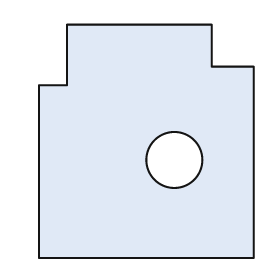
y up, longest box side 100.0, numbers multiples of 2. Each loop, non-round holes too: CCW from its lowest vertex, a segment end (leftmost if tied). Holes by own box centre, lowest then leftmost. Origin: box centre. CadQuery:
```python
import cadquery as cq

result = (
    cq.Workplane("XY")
    .moveTo(-46.0, -50.0)
    .lineTo(46.0, -50.0)
    .lineTo(46.0, 32.0)
    .lineTo(28.0, 32.0)
    .lineTo(28.0, 50.0)
    .lineTo(-34.0, 50.0)
    .lineTo(-34.0, 24.0)
    .lineTo(-46.0, 24.0)
    .close()
    .moveTo(12.0, -8.0)
    .circle(12.0)
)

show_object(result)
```